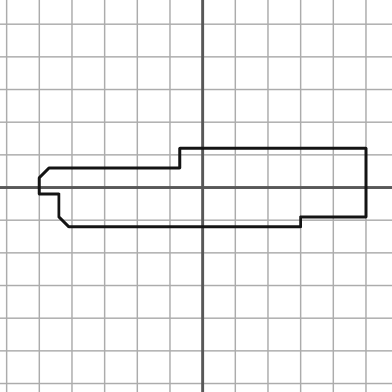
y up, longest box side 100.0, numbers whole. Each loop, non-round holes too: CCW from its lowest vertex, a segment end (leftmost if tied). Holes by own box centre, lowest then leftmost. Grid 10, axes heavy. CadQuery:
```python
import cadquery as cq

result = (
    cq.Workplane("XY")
    .moveTo(-41.0, -12.0)
    .lineTo(30.0, -12.0)
    .lineTo(30.0, -9.0)
    .lineTo(50.0, -9.0)
    .lineTo(50.0, 12.0)
    .lineTo(-7.0, 12.0)
    .lineTo(-7.0, 6.0)
    .lineTo(-47.0, 6.0)
    .lineTo(-50.0, 3.0)
    .lineTo(-50.0, -2.0)
    .lineTo(-44.0, -2.0)
    .lineTo(-44.0, -9.0)
    .close()
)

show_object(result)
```